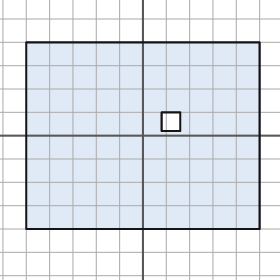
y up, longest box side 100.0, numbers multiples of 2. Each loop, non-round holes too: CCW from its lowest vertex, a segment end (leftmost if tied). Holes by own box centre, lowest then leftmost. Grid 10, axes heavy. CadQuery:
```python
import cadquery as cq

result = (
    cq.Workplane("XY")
    .moveTo(-50.0, -40.0)
    .lineTo(50.0, -40.0)
    .lineTo(50.0, 40.0)
    .lineTo(-50.0, 40.0)
    .close()
    .moveTo(8.0, 2.0)
    .lineTo(16.0, 2.0)
    .lineTo(16.0, 10.0)
    .lineTo(8.0, 10.0)
    .close()
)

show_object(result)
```